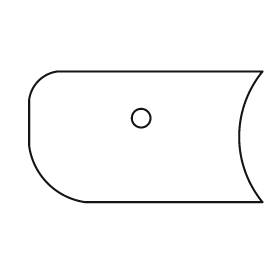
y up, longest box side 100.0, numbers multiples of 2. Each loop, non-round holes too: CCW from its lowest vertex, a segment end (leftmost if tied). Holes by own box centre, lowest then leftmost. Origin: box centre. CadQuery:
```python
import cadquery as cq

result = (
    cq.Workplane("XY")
    .moveTo(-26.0, -28.0)
    .lineTo(50.0, -28.0)
    .threePointArc((40.0, 0.0), (50.0, 28.0))
    .lineTo(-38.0, 28.0)
    .threePointArc((-46.0, 24.0), (-50.0, 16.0))
    .lineTo(-50.0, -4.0)
    .threePointArc((-42.0, -20.0), (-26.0, -28.0))
    .close()
    .moveTo(-2.0, 8.0)
    .circle(4.0)
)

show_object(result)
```